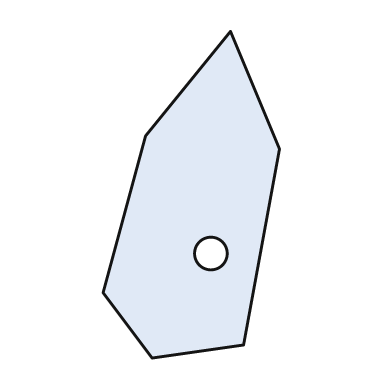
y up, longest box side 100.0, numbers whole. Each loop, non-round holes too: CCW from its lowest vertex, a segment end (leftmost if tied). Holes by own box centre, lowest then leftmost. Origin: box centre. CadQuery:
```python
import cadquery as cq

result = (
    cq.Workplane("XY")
    .moveTo(-12.0, -50.0)
    .lineTo(16.0, -46.0)
    .lineTo(27.0, 14.0)
    .lineTo(12.0, 50.0)
    .lineTo(-14.0, 18.0)
    .lineTo(-27.0, -30.0)
    .close()
    .moveTo(6.0, -18.0)
    .circle(5.0)
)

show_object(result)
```